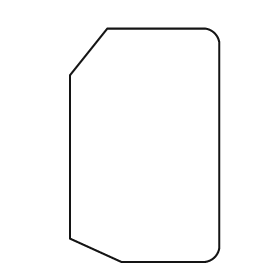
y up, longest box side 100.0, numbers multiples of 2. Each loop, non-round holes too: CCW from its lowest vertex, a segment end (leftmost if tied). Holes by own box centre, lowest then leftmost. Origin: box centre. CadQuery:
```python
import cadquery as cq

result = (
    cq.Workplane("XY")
    .moveTo(-10.0, -50.0)
    .lineTo(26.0, -50.0)
    .threePointArc((30.0, -48.0), (32.0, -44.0))
    .lineTo(32.0, 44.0)
    .threePointArc((30.0, 48.0), (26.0, 50.0))
    .lineTo(-16.0, 50.0)
    .lineTo(-32.0, 30.0)
    .lineTo(-32.0, -40.0)
    .close()
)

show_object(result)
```